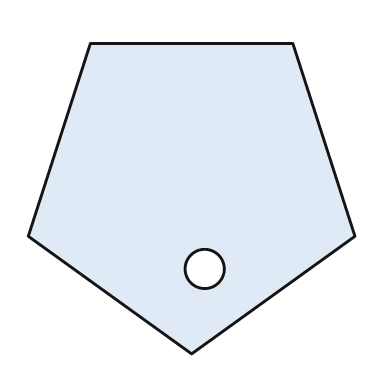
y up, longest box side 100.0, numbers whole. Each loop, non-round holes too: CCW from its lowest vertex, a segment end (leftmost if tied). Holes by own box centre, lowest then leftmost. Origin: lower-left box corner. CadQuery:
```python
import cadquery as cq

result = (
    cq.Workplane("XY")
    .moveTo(50.0, 0.0)
    .lineTo(100.0, 36.0)
    .lineTo(81.0, 95.0)
    .lineTo(19.0, 95.0)
    .lineTo(0.0, 36.0)
    .close()
    .moveTo(54.0, 26.0)
    .circle(6.0)
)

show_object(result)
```